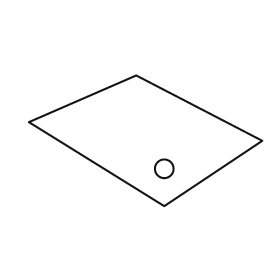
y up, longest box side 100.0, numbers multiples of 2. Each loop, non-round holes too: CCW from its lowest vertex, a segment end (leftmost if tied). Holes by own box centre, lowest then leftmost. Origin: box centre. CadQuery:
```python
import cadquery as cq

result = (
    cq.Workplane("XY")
    .moveTo(8.0, -28.0)
    .lineTo(50.0, 0.0)
    .lineTo(-4.0, 28.0)
    .lineTo(-50.0, 8.0)
    .close()
    .moveTo(8.0, -12.0)
    .circle(4.0)
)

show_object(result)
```